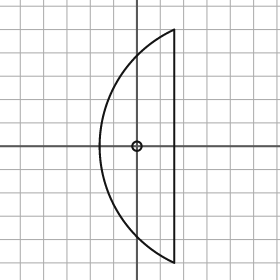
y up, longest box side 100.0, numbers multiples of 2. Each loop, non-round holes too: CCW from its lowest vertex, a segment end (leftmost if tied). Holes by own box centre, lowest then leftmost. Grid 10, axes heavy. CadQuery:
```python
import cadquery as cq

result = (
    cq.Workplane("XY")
    .moveTo(16.0, -50.0)
    .lineTo(16.0, 50.0)
    .threePointArc((-16.0, 0.0), (16.0, -50.0))
    .close()
    .moveTo(0.0, 0.0)
    .circle(2.0)
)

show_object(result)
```